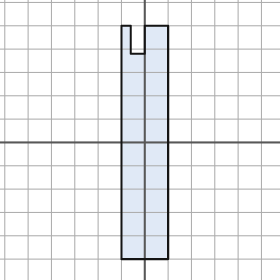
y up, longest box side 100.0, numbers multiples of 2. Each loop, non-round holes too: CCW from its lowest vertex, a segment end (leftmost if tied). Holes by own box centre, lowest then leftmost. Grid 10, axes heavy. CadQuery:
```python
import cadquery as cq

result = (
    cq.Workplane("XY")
    .moveTo(-10.0, -50.0)
    .lineTo(10.0, -50.0)
    .lineTo(10.0, 50.0)
    .lineTo(0.0, 50.0)
    .lineTo(0.0, 38.0)
    .lineTo(-6.0, 38.0)
    .lineTo(-6.0, 50.0)
    .lineTo(-10.0, 50.0)
    .close()
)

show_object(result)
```